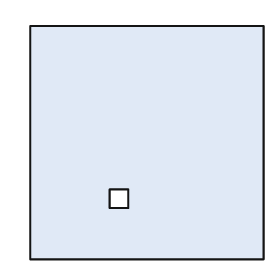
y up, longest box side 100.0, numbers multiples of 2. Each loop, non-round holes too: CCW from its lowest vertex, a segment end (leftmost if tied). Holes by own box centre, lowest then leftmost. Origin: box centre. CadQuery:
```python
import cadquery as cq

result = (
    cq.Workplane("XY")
    .moveTo(-50.0, -50.0)
    .lineTo(50.0, -50.0)
    .lineTo(50.0, 50.0)
    .lineTo(-50.0, 50.0)
    .close()
    .moveTo(-16.0, -28.0)
    .lineTo(-8.0, -28.0)
    .lineTo(-8.0, -20.0)
    .lineTo(-16.0, -20.0)
    .close()
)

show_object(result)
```